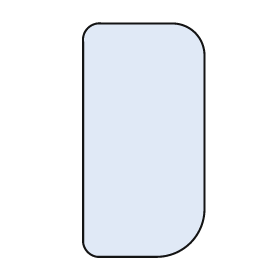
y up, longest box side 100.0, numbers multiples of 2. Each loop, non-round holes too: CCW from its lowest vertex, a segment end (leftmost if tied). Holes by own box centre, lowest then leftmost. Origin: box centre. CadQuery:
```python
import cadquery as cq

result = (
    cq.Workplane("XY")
    .moveTo(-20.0, -50.0)
    .lineTo(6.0, -50.0)
    .threePointArc((20.0, -44.0), (26.0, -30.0))
    .lineTo(26.0, 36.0)
    .threePointArc((22.0, 46.0), (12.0, 50.0))
    .lineTo(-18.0, 50.0)
    .threePointArc((-24.0, 48.0), (-26.0, 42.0))
    .lineTo(-26.0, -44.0)
    .threePointArc((-24.0, -48.0), (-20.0, -50.0))
    .close()
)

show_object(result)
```